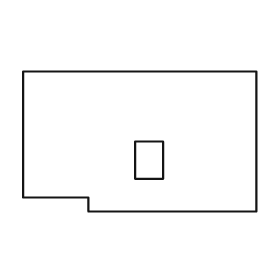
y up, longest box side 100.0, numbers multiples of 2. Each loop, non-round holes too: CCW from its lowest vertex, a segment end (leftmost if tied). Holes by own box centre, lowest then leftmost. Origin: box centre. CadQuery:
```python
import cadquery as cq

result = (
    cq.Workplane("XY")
    .moveTo(-22.0, -30.0)
    .lineTo(50.0, -30.0)
    .lineTo(50.0, 30.0)
    .lineTo(-50.0, 30.0)
    .lineTo(-50.0, -24.0)
    .lineTo(-22.0, -24.0)
    .close()
    .moveTo(-2.0, -16.0)
    .lineTo(10.0, -16.0)
    .lineTo(10.0, 0.0)
    .lineTo(-2.0, 0.0)
    .close()
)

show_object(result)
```